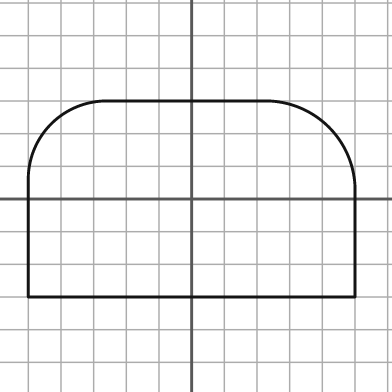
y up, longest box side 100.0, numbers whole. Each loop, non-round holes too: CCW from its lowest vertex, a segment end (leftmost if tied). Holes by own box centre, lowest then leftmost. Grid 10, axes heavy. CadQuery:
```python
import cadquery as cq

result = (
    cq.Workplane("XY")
    .moveTo(-50.0, -30.0)
    .lineTo(50.0, -30.0)
    .lineTo(50.0, 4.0)
    .threePointArc((42.0, 22.0), (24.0, 30.0))
    .lineTo(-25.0, 30.0)
    .threePointArc((-43.0, 23.0), (-50.0, 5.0))
    .close()
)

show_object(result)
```